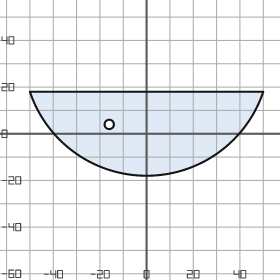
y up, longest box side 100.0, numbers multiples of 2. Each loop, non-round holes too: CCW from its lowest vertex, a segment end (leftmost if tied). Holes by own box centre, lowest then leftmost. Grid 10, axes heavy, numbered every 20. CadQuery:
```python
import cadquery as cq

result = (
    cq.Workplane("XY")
    .moveTo(-50.0, 18.0)
    .threePointArc((0.0, -18.0), (50.0, 18.0))
    .close()
    .moveTo(-16.0, 4.0)
    .circle(2.0)
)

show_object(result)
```